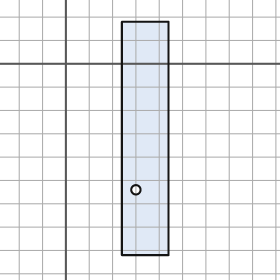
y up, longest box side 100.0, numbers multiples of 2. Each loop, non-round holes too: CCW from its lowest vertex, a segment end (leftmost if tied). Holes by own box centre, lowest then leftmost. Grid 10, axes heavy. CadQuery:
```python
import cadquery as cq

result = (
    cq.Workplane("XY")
    .moveTo(24.0, -82.0)
    .lineTo(44.0, -82.0)
    .lineTo(44.0, 18.0)
    .lineTo(24.0, 18.0)
    .close()
    .moveTo(30.0, -54.0)
    .circle(2.0)
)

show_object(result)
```